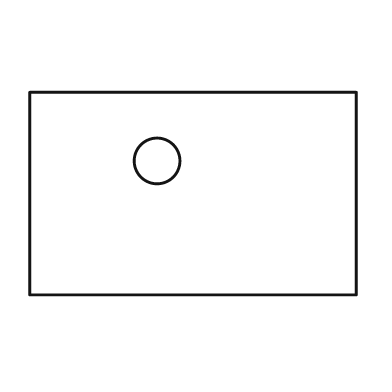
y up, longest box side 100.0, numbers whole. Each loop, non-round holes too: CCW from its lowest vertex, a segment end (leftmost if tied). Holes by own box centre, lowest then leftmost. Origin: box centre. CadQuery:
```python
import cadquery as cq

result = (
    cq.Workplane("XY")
    .moveTo(-50.0, -31.0)
    .lineTo(50.0, -31.0)
    .lineTo(50.0, 31.0)
    .lineTo(-50.0, 31.0)
    .close()
    .moveTo(-11.0, 10.0)
    .circle(7.0)
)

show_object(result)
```